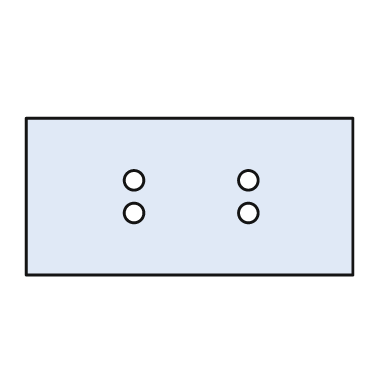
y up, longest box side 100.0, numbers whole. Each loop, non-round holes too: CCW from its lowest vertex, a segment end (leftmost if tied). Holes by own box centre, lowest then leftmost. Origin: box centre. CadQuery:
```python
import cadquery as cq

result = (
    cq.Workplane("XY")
    .moveTo(-50.0, -24.0)
    .lineTo(50.0, -24.0)
    .lineTo(50.0, 24.0)
    .lineTo(-50.0, 24.0)
    .close()
    .moveTo(-17.0, -5.0)
    .circle(3.0)
    .moveTo(18.0, -5.0)
    .circle(3.0)
    .moveTo(-17.0, 5.0)
    .circle(3.0)
    .moveTo(18.0, 5.0)
    .circle(3.0)
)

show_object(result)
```